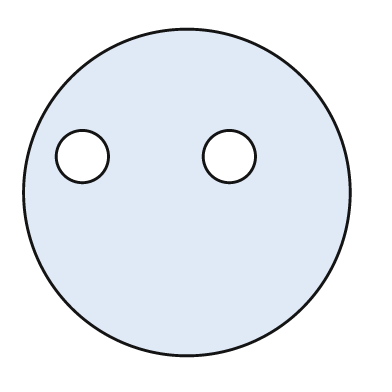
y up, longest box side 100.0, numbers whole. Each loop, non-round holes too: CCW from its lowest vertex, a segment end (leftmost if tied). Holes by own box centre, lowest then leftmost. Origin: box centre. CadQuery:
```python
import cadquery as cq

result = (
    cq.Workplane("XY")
    .moveTo(0.0, 0.0)
    .circle(50.0)
    .moveTo(-32.0, 11.0)
    .circle(8.0)
    .moveTo(13.0, 11.0)
    .circle(8.0)
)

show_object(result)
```